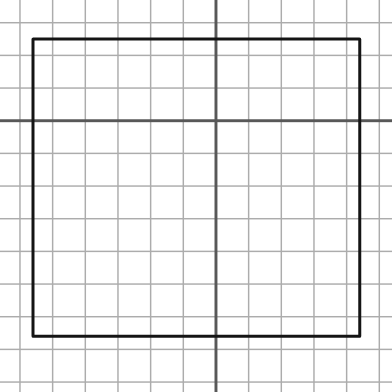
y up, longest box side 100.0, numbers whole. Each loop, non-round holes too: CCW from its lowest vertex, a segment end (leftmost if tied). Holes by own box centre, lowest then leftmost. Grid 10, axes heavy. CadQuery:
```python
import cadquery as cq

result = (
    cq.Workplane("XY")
    .moveTo(-56.0, -66.0)
    .lineTo(44.0, -66.0)
    .lineTo(44.0, 25.0)
    .lineTo(-56.0, 25.0)
    .close()
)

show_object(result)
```